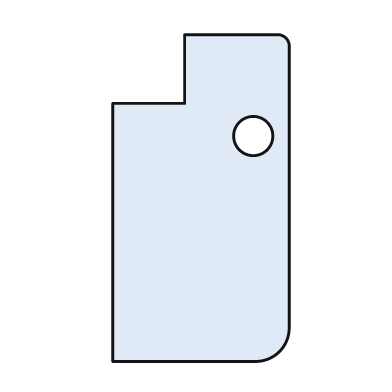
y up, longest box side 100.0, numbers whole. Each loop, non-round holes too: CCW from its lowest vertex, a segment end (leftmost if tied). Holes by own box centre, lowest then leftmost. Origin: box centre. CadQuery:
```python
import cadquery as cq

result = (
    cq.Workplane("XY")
    .moveTo(-27.0, -50.0)
    .lineTo(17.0, -50.0)
    .threePointArc((24.0, -47.0), (27.0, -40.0))
    .lineTo(27.0, 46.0)
    .threePointArc((26.0, 49.0), (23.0, 50.0))
    .lineTo(-5.0, 50.0)
    .lineTo(-5.0, 29.0)
    .lineTo(-27.0, 29.0)
    .close()
    .moveTo(16.0, 19.0)
    .circle(6.0)
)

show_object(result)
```